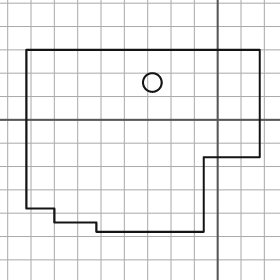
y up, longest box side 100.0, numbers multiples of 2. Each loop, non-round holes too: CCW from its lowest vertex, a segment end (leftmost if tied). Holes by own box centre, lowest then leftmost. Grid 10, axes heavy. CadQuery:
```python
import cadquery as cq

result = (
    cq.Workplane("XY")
    .moveTo(-52.0, -48.0)
    .lineTo(-6.0, -48.0)
    .lineTo(-6.0, -16.0)
    .lineTo(18.0, -16.0)
    .lineTo(18.0, 30.0)
    .lineTo(-82.0, 30.0)
    .lineTo(-82.0, -38.0)
    .lineTo(-70.0, -38.0)
    .lineTo(-70.0, -44.0)
    .lineTo(-52.0, -44.0)
    .close()
    .moveTo(-28.0, 16.0)
    .circle(4.0)
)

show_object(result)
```